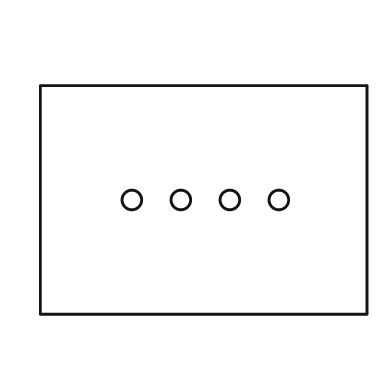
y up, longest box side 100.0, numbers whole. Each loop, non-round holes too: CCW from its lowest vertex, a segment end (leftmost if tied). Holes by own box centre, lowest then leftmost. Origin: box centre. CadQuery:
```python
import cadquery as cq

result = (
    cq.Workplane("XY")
    .moveTo(-50.0, -35.0)
    .lineTo(50.0, -35.0)
    .lineTo(50.0, 35.0)
    .lineTo(-50.0, 35.0)
    .close()
    .moveTo(-22.0, 0.0)
    .circle(3.0)
    .moveTo(-7.0, 0.0)
    .circle(3.0)
    .moveTo(8.0, 0.0)
    .circle(3.0)
    .moveTo(23.0, 0.0)
    .circle(3.0)
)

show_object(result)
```